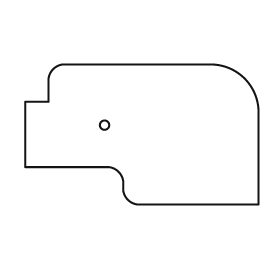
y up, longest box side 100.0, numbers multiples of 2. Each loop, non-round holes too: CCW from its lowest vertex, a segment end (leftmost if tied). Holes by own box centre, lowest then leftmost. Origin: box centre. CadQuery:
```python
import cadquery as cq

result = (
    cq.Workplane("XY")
    .moveTo(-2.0, -30.0)
    .lineTo(50.0, -30.0)
    .lineTo(50.0, 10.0)
    .threePointArc((44.0, 24.0), (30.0, 30.0))
    .lineTo(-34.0, 30.0)
    .threePointArc((-38.0, 28.0), (-40.0, 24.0))
    .lineTo(-40.0, 14.0)
    .lineTo(-50.0, 14.0)
    .lineTo(-50.0, -14.0)
    .lineTo(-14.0, -14.0)
    .threePointArc((-10.0, -16.0), (-8.0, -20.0))
    .lineTo(-8.0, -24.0)
    .threePointArc((-6.0, -28.0), (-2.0, -30.0))
    .close()
    .moveTo(-16.0, 4.0)
    .circle(2.0)
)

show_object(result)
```